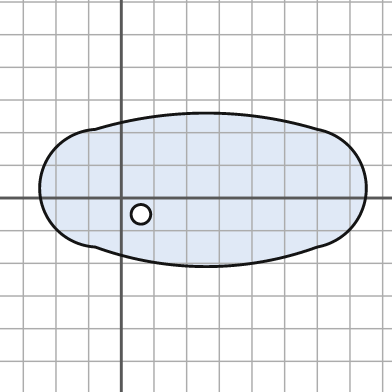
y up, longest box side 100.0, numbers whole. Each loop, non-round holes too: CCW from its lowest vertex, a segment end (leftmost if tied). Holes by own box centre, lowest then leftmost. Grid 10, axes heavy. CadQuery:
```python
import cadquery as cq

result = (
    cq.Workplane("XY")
    .moveTo(-8.0, -15.0)
    .threePointArc((26.0, -21.0), (60.0, -15.0))
    .threePointArc((75.0, 3.0), (60.0, 21.0))
    .threePointArc((26.0, 26.0), (-8.0, 21.0))
    .threePointArc((-25.0, 3.0), (-8.0, -15.0))
    .close()
    .moveTo(6.0, -5.0)
    .circle(3.0)
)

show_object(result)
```